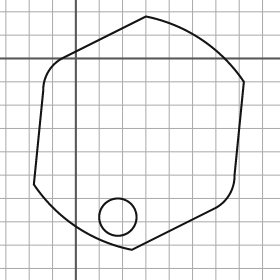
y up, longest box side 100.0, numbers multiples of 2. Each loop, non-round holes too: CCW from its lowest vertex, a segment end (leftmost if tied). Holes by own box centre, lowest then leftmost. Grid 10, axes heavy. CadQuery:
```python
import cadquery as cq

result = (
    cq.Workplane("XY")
    .moveTo(24.0, -82.0)
    .lineTo(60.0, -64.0)
    .threePointArc((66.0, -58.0), (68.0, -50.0))
    .lineTo(72.0, -10.0)
    .threePointArc((54.0, 8.0), (30.0, 18.0))
    .lineTo(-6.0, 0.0)
    .threePointArc((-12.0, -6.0), (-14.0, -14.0))
    .lineTo(-18.0, -54.0)
    .threePointArc((0.0, -72.0), (24.0, -82.0))
    .close()
    .moveTo(18.0, -68.0)
    .circle(8.0)
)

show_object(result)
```